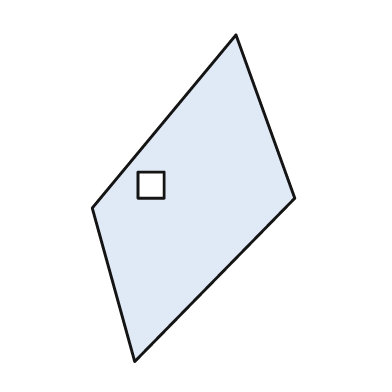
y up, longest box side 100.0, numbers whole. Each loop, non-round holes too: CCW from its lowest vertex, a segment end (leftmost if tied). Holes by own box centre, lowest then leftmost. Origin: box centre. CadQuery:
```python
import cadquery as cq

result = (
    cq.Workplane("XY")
    .moveTo(-18.0, -50.0)
    .lineTo(31.0, 0.0)
    .lineTo(13.0, 50.0)
    .lineTo(-31.0, -3.0)
    .close()
    .moveTo(-17.0, 0.0)
    .lineTo(-9.0, 0.0)
    .lineTo(-9.0, 8.0)
    .lineTo(-17.0, 8.0)
    .close()
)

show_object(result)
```